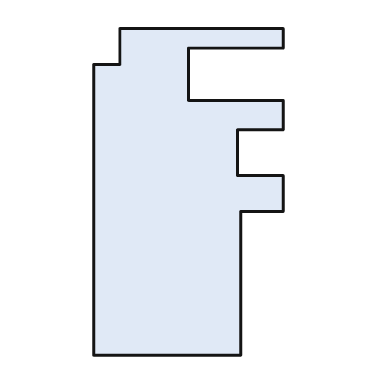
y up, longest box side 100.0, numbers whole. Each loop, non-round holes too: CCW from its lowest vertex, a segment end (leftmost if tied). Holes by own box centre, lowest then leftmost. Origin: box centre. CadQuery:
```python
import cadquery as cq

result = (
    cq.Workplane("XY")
    .moveTo(-29.0, -50.0)
    .lineTo(16.0, -50.0)
    .lineTo(16.0, -6.0)
    .lineTo(29.0, -6.0)
    .lineTo(29.0, 5.0)
    .lineTo(15.0, 5.0)
    .lineTo(15.0, 19.0)
    .lineTo(29.0, 19.0)
    .lineTo(29.0, 28.0)
    .lineTo(0.0, 28.0)
    .lineTo(0.0, 44.0)
    .lineTo(29.0, 44.0)
    .lineTo(29.0, 50.0)
    .lineTo(-21.0, 50.0)
    .lineTo(-21.0, 39.0)
    .lineTo(-29.0, 39.0)
    .close()
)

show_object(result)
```